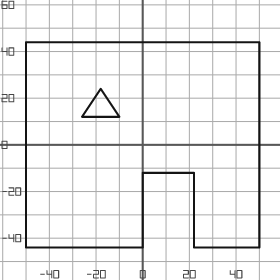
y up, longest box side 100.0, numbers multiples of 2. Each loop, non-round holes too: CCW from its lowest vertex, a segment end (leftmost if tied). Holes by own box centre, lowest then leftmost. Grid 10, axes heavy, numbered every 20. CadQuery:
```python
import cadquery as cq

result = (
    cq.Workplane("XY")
    .moveTo(-50.0, -44.0)
    .lineTo(0.0, -44.0)
    .lineTo(0.0, -12.0)
    .lineTo(22.0, -12.0)
    .lineTo(22.0, -44.0)
    .lineTo(50.0, -44.0)
    .lineTo(50.0, 44.0)
    .lineTo(-50.0, 44.0)
    .close()
    .moveTo(-26.0, 12.0)
    .lineTo(-10.0, 12.0)
    .lineTo(-18.0, 24.0)
    .close()
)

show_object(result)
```